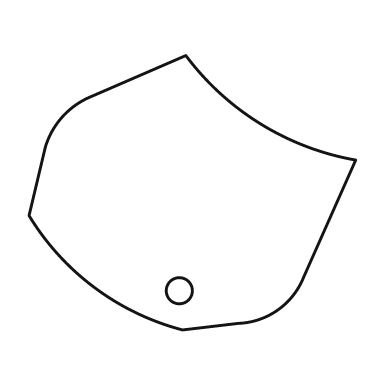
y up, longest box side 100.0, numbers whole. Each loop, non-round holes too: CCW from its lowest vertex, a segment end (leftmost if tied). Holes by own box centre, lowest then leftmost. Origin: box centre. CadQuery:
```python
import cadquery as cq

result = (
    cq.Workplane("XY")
    .moveTo(-3.0, -42.0)
    .lineTo(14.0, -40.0)
    .threePointArc((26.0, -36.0), (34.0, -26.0))
    .lineTo(50.0, 10.0)
    .threePointArc((21.0, 21.0), (-2.0, 42.0))
    .lineTo(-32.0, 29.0)
    .threePointArc((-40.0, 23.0), (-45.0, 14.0))
    .lineTo(-50.0, -7.0)
    .threePointArc((-30.0, -29.0), (-3.0, -42.0))
    .close()
    .moveTo(-4.0, -30.0)
    .circle(4.0)
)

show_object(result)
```